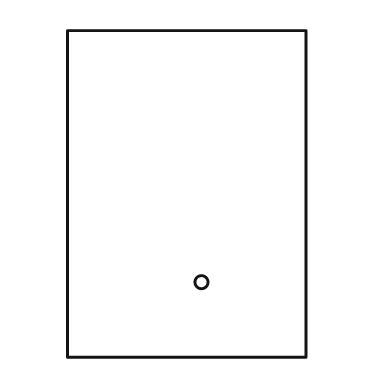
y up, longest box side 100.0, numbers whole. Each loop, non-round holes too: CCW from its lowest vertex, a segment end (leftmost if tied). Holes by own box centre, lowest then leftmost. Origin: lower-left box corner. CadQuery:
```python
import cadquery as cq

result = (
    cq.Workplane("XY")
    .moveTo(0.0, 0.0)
    .lineTo(73.0, 0.0)
    .lineTo(73.0, 100.0)
    .lineTo(0.0, 100.0)
    .close()
    .moveTo(41.0, 23.0)
    .circle(2.0)
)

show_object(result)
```